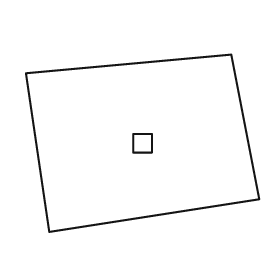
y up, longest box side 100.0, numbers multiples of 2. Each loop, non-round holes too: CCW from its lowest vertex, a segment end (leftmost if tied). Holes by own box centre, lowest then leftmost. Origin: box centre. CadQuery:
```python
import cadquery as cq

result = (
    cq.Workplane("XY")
    .moveTo(-40.0, -38.0)
    .lineTo(50.0, -24.0)
    .lineTo(38.0, 38.0)
    .lineTo(-50.0, 30.0)
    .close()
    .moveTo(-4.0, -4.0)
    .lineTo(4.0, -4.0)
    .lineTo(4.0, 4.0)
    .lineTo(-4.0, 4.0)
    .close()
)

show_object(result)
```